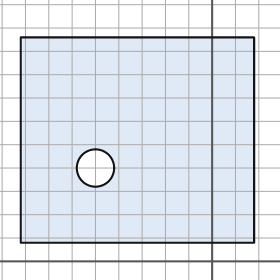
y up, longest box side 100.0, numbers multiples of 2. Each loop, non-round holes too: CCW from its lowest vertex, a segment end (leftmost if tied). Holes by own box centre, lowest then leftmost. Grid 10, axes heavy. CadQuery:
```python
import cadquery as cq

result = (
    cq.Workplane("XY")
    .moveTo(-82.0, 8.0)
    .lineTo(18.0, 8.0)
    .lineTo(18.0, 96.0)
    .lineTo(-82.0, 96.0)
    .close()
    .moveTo(-50.0, 40.0)
    .circle(8.0)
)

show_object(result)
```